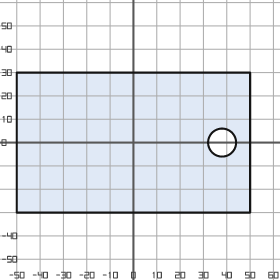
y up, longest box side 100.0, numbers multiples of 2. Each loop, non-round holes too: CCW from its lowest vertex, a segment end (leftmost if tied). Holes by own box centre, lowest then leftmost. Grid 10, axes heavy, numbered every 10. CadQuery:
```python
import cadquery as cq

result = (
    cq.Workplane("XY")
    .moveTo(-50.0, -30.0)
    .lineTo(50.0, -30.0)
    .lineTo(50.0, 30.0)
    .lineTo(-50.0, 30.0)
    .close()
    .moveTo(38.0, 0.0)
    .circle(6.0)
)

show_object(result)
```